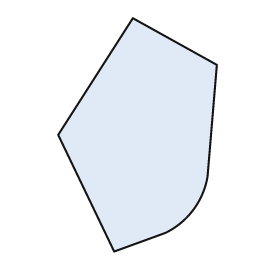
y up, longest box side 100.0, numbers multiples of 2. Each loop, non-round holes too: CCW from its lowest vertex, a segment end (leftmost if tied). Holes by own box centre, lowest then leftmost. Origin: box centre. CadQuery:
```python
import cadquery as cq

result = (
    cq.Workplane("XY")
    .moveTo(-10.0, -50.0)
    .lineTo(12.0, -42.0)
    .threePointArc((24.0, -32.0), (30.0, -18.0))
    .lineTo(34.0, 30.0)
    .lineTo(-2.0, 50.0)
    .lineTo(-34.0, 0.0)
    .close()
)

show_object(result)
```